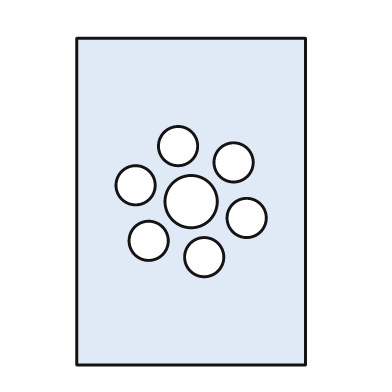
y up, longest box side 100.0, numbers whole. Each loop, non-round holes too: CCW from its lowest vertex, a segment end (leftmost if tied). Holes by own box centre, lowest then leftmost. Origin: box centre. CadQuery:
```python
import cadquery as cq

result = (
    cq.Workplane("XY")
    .moveTo(-35.0, -50.0)
    .lineTo(35.0, -50.0)
    .lineTo(35.0, 50.0)
    .lineTo(-35.0, 50.0)
    .close()
    .moveTo(4.0, -17.0)
    .circle(6.0)
    .moveTo(-13.0, -12.0)
    .circle(6.0)
    .moveTo(17.0, -5.0)
    .circle(6.0)
    .moveTo(0.0, 0.0)
    .circle(8.0)
    .moveTo(-17.0, 5.0)
    .circle(6.0)
    .moveTo(13.0, 12.0)
    .circle(6.0)
    .moveTo(-4.0, 17.0)
    .circle(6.0)
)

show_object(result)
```